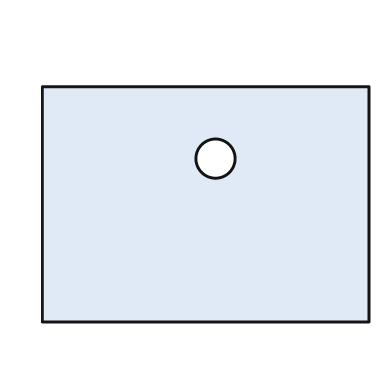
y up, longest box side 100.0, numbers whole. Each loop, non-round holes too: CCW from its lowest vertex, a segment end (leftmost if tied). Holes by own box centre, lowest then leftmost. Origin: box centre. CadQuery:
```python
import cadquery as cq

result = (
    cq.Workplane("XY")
    .moveTo(-50.0, -36.0)
    .lineTo(50.0, -36.0)
    .lineTo(50.0, 36.0)
    .lineTo(-50.0, 36.0)
    .close()
    .moveTo(3.0, 14.0)
    .circle(6.0)
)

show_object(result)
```